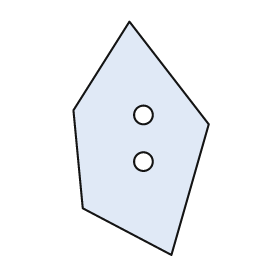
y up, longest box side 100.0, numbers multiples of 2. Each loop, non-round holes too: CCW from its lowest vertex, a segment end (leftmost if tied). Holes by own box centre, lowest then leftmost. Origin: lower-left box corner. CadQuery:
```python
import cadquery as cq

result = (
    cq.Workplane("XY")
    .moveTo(42.0, 0.0)
    .lineTo(58.0, 56.0)
    .lineTo(24.0, 100.0)
    .lineTo(0.0, 62.0)
    .lineTo(4.0, 20.0)
    .close()
    .moveTo(30.0, 40.0)
    .circle(4.0)
    .moveTo(30.0, 60.0)
    .circle(4.0)
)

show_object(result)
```